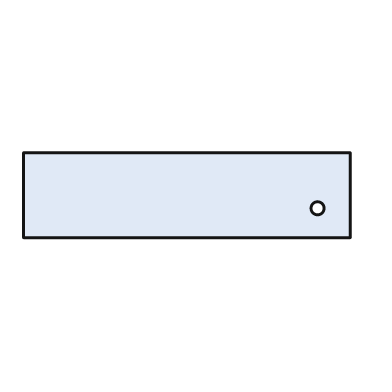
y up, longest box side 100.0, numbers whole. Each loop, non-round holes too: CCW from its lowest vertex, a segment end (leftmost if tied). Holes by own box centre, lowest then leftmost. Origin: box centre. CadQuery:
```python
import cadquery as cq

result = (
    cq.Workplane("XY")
    .moveTo(-50.0, -13.0)
    .lineTo(50.0, -13.0)
    .lineTo(50.0, 13.0)
    .lineTo(-50.0, 13.0)
    .close()
    .moveTo(40.0, -4.0)
    .circle(2.0)
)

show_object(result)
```